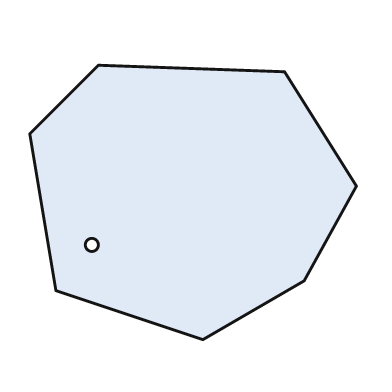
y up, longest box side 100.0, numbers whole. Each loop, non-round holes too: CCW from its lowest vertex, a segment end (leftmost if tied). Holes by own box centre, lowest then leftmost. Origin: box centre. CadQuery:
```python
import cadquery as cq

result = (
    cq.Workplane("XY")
    .moveTo(3.0, -42.0)
    .lineTo(34.0, -24.0)
    .lineTo(50.0, 5.0)
    .lineTo(28.0, 40.0)
    .lineTo(-29.0, 42.0)
    .lineTo(-50.0, 21.0)
    .lineTo(-42.0, -27.0)
    .close()
    .moveTo(-31.0, -13.0)
    .circle(2.0)
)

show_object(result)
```